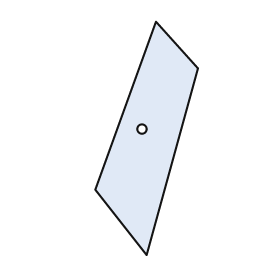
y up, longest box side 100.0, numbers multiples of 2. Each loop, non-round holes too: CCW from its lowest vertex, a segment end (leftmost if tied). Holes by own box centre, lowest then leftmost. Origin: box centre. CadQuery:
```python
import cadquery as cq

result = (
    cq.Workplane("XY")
    .moveTo(0.0, -50.0)
    .lineTo(22.0, 30.0)
    .lineTo(4.0, 50.0)
    .lineTo(-22.0, -22.0)
    .close()
    .moveTo(-2.0, 4.0)
    .circle(2.0)
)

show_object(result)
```